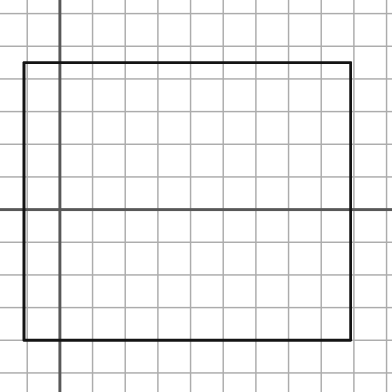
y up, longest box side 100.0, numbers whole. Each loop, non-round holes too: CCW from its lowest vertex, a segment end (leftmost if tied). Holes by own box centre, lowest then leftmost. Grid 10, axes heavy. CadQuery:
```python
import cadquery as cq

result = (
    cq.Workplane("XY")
    .moveTo(-11.0, -40.0)
    .lineTo(89.0, -40.0)
    .lineTo(89.0, 45.0)
    .lineTo(-11.0, 45.0)
    .close()
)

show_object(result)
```